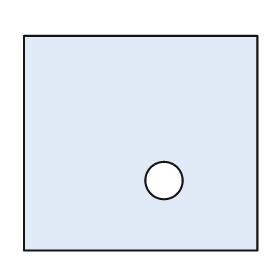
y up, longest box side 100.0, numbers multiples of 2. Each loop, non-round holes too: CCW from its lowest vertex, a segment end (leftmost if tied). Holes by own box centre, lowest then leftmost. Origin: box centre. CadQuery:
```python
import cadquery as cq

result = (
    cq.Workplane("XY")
    .moveTo(-50.0, -46.0)
    .lineTo(50.0, -46.0)
    .lineTo(50.0, 46.0)
    .lineTo(-50.0, 46.0)
    .close()
    .moveTo(10.0, -16.0)
    .circle(8.0)
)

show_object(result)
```